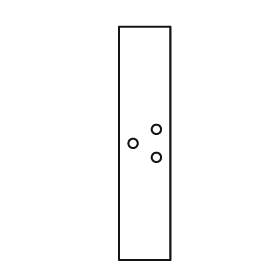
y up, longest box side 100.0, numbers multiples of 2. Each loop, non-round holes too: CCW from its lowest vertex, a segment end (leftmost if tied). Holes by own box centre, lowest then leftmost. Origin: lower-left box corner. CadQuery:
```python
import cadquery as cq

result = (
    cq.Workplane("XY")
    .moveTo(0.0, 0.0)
    .lineTo(22.0, 0.0)
    .lineTo(22.0, 100.0)
    .lineTo(0.0, 100.0)
    .close()
    .moveTo(16.0, 44.0)
    .circle(2.0)
    .moveTo(6.0, 50.0)
    .circle(2.0)
    .moveTo(16.0, 56.0)
    .circle(2.0)
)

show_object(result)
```